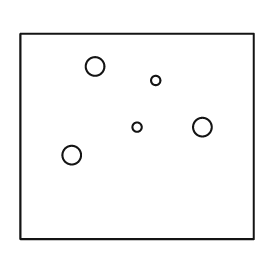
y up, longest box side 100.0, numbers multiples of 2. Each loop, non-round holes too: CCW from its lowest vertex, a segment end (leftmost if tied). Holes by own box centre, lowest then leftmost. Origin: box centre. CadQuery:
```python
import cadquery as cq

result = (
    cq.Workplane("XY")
    .moveTo(-50.0, -44.0)
    .lineTo(50.0, -44.0)
    .lineTo(50.0, 44.0)
    .lineTo(-50.0, 44.0)
    .close()
    .moveTo(-28.0, -8.0)
    .circle(4.0)
    .moveTo(0.0, 4.0)
    .circle(2.0)
    .moveTo(28.0, 4.0)
    .circle(4.0)
    .moveTo(8.0, 24.0)
    .circle(2.0)
    .moveTo(-18.0, 30.0)
    .circle(4.0)
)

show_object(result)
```